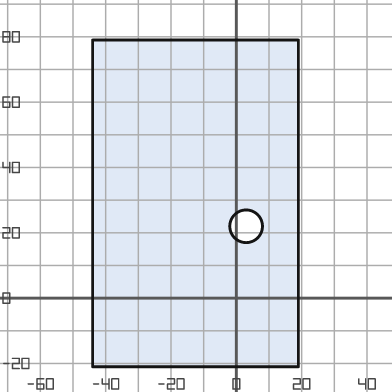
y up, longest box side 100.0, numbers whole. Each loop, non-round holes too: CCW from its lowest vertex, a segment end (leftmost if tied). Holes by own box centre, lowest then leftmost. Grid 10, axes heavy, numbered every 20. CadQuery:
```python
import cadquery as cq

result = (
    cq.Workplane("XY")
    .moveTo(-44.0, -21.0)
    .lineTo(19.0, -21.0)
    .lineTo(19.0, 79.0)
    .lineTo(-44.0, 79.0)
    .close()
    .moveTo(3.0, 22.0)
    .circle(5.0)
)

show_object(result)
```